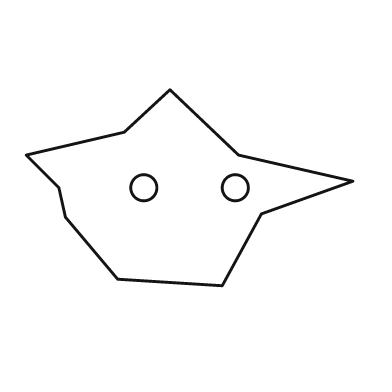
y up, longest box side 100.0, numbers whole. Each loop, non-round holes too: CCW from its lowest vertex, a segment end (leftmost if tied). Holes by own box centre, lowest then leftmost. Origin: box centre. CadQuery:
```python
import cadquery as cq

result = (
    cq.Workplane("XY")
    .moveTo(10.0, -30.0)
    .lineTo(22.0, -8.0)
    .lineTo(50.0, 2.0)
    .lineTo(15.0, 10.0)
    .lineTo(-6.0, 30.0)
    .lineTo(-20.0, 17.0)
    .lineTo(-50.0, 10.0)
    .lineTo(-40.0, 0.0)
    .lineTo(-38.0, -9.0)
    .lineTo(-22.0, -28.0)
    .close()
    .moveTo(-14.0, 0.0)
    .circle(4.0)
    .moveTo(14.0, 0.0)
    .circle(4.0)
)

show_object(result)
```